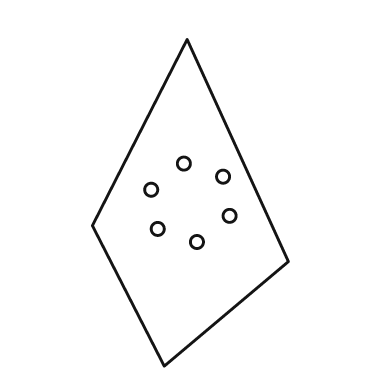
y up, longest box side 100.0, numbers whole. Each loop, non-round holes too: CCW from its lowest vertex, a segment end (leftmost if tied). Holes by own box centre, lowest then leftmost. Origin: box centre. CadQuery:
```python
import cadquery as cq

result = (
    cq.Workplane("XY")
    .moveTo(-8.0, -50.0)
    .lineTo(30.0, -18.0)
    .lineTo(-1.0, 50.0)
    .lineTo(-30.0, -7.0)
    .close()
    .moveTo(2.0, -12.0)
    .circle(2.0)
    .moveTo(-10.0, -8.0)
    .circle(2.0)
    .moveTo(12.0, -4.0)
    .circle(2.0)
    .moveTo(-12.0, 4.0)
    .circle(2.0)
    .moveTo(10.0, 8.0)
    .circle(2.0)
    .moveTo(-2.0, 12.0)
    .circle(2.0)
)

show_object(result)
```